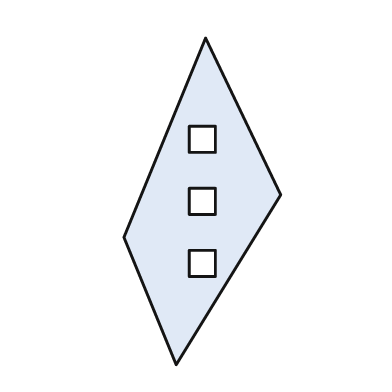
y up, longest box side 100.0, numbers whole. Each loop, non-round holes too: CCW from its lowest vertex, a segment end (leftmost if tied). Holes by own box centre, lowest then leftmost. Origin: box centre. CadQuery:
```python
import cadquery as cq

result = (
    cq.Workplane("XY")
    .moveTo(-8.0, -50.0)
    .lineTo(24.0, 2.0)
    .lineTo(1.0, 50.0)
    .lineTo(-24.0, -11.0)
    .close()
    .moveTo(-4.0, -23.0)
    .lineTo(4.0, -23.0)
    .lineTo(4.0, -15.0)
    .lineTo(-4.0, -15.0)
    .close()
    .moveTo(-4.0, -4.0)
    .lineTo(4.0, -4.0)
    .lineTo(4.0, 4.0)
    .lineTo(-4.0, 4.0)
    .close()
    .moveTo(-4.0, 15.0)
    .lineTo(4.0, 15.0)
    .lineTo(4.0, 23.0)
    .lineTo(-4.0, 23.0)
    .close()
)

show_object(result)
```